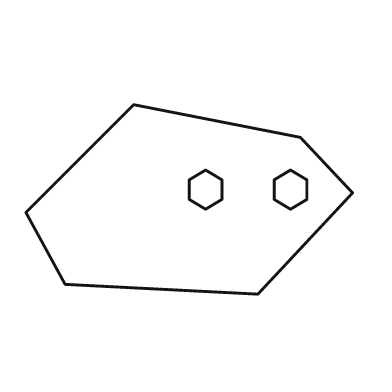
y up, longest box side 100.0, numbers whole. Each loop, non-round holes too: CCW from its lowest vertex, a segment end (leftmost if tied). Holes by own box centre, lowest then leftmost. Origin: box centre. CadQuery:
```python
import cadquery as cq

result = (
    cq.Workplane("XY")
    .moveTo(21.0, -29.0)
    .lineTo(50.0, 2.0)
    .lineTo(34.0, 19.0)
    .lineTo(-17.0, 29.0)
    .lineTo(-50.0, -4.0)
    .lineTo(-38.0, -26.0)
    .close()
    .moveTo(5.0, -3.0)
    .lineTo(10.0, 0.0)
    .lineTo(10.0, 6.0)
    .lineTo(5.0, 9.0)
    .lineTo(0.0, 6.0)
    .lineTo(0.0, 0.0)
    .close()
    .moveTo(31.0, -3.0)
    .lineTo(36.0, 0.0)
    .lineTo(36.0, 6.0)
    .lineTo(31.0, 9.0)
    .lineTo(26.0, 6.0)
    .lineTo(26.0, 0.0)
    .close()
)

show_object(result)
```